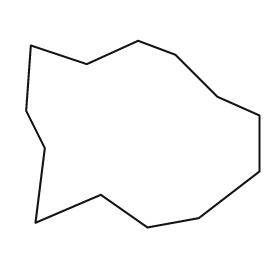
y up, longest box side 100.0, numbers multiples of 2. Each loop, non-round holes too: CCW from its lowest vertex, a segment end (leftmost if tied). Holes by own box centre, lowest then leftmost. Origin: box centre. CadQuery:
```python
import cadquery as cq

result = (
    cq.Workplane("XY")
    .moveTo(2.0, -40.0)
    .lineTo(24.0, -36.0)
    .lineTo(50.0, -16.0)
    .lineTo(50.0, 8.0)
    .lineTo(32.0, 16.0)
    .lineTo(14.0, 34.0)
    .lineTo(-2.0, 40.0)
    .lineTo(-24.0, 30.0)
    .lineTo(-48.0, 38.0)
    .lineTo(-50.0, 10.0)
    .lineTo(-42.0, -6.0)
    .lineTo(-46.0, -38.0)
    .lineTo(-18.0, -26.0)
    .close()
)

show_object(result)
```